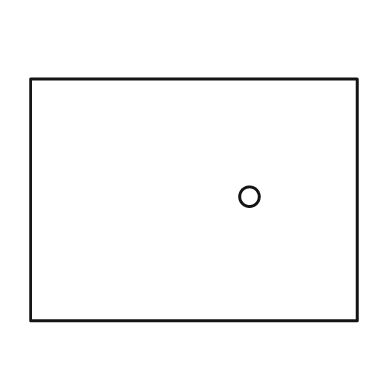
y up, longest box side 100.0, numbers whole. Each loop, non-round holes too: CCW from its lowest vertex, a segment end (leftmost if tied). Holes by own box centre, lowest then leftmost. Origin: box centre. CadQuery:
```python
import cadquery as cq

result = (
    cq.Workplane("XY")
    .moveTo(-50.0, -37.0)
    .lineTo(50.0, -37.0)
    .lineTo(50.0, 37.0)
    .lineTo(-50.0, 37.0)
    .close()
    .moveTo(17.0, 1.0)
    .circle(3.0)
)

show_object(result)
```